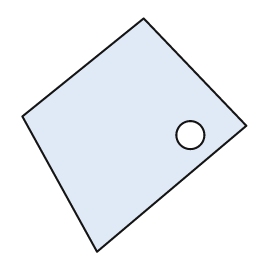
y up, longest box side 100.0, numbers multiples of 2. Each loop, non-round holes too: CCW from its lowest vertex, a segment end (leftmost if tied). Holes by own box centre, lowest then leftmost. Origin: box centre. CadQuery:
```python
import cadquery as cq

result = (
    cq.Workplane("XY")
    .moveTo(-16.0, -50.0)
    .lineTo(48.0, 4.0)
    .lineTo(4.0, 50.0)
    .lineTo(-48.0, 8.0)
    .close()
    .moveTo(24.0, 0.0)
    .circle(6.0)
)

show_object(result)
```